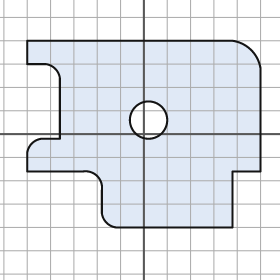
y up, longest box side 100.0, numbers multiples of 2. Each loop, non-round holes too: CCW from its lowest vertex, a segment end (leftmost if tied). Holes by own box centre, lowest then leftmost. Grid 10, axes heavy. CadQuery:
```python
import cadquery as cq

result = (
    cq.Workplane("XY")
    .moveTo(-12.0, -40.0)
    .lineTo(38.0, -40.0)
    .lineTo(38.0, -16.0)
    .lineTo(50.0, -16.0)
    .lineTo(50.0, 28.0)
    .threePointArc((46.0, 36.0), (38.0, 40.0))
    .lineTo(-50.0, 40.0)
    .lineTo(-50.0, 30.0)
    .lineTo(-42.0, 30.0)
    .threePointArc((-38.0, 28.0), (-36.0, 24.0))
    .lineTo(-36.0, -2.0)
    .lineTo(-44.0, -2.0)
    .threePointArc((-48.0, -4.0), (-50.0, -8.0))
    .lineTo(-50.0, -16.0)
    .lineTo(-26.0, -16.0)
    .threePointArc((-20.0, -18.0), (-18.0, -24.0))
    .lineTo(-18.0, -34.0)
    .threePointArc((-16.0, -38.0), (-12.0, -40.0))
    .close()
    .moveTo(2.0, 6.0)
    .circle(8.0)
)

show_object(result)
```